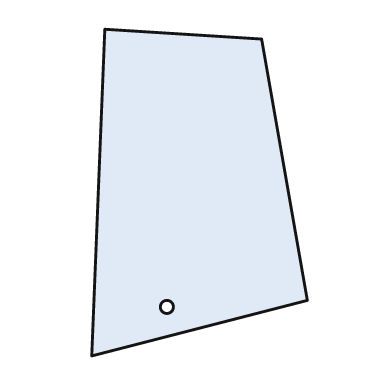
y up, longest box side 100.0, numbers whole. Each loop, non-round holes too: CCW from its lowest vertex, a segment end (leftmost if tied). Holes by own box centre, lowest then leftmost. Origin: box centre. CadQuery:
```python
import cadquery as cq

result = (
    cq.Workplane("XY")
    .moveTo(-33.0, -50.0)
    .lineTo(33.0, -33.0)
    .lineTo(19.0, 47.0)
    .lineTo(-29.0, 50.0)
    .close()
    .moveTo(-10.0, -35.0)
    .circle(2.0)
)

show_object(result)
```